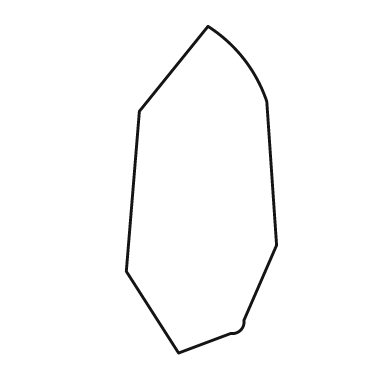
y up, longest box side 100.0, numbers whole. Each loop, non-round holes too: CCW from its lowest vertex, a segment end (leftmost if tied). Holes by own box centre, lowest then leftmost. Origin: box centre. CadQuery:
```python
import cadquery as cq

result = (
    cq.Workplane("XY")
    .moveTo(-7.0, -50.0)
    .lineTo(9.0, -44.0)
    .threePointArc((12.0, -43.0), (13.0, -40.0))
    .lineTo(23.0, -17.0)
    .lineTo(20.0, 27.0)
    .threePointArc((13.0, 40.0), (2.0, 50.0))
    .lineTo(-19.0, 24.0)
    .lineTo(-23.0, -25.0)
    .close()
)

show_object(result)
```